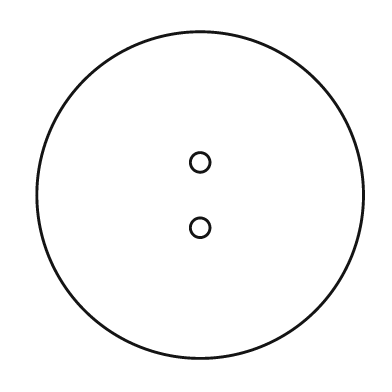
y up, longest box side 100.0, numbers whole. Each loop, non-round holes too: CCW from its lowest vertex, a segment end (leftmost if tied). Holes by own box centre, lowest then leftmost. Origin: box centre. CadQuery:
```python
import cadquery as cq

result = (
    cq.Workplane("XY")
    .moveTo(0.0, 0.0)
    .circle(50.0)
    .moveTo(0.0, -10.0)
    .circle(3.0)
    .moveTo(0.0, 10.0)
    .circle(3.0)
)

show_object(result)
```